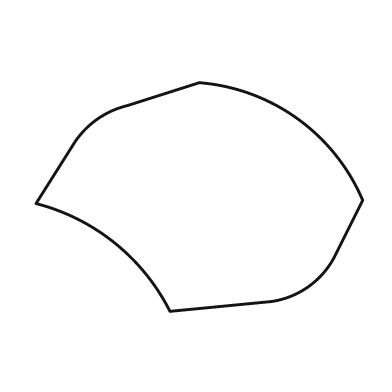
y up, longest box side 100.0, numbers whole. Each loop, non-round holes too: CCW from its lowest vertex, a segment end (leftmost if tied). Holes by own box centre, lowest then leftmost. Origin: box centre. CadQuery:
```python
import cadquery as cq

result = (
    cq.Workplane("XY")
    .moveTo(-9.0, -35.0)
    .lineTo(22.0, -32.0)
    .threePointArc((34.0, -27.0), (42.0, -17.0))
    .lineTo(50.0, -1.0)
    .threePointArc((30.0, 24.0), (0.0, 35.0))
    .lineTo(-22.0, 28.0)
    .threePointArc((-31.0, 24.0), (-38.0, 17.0))
    .lineTo(-50.0, -2.0)
    .threePointArc((-26.0, -14.0), (-9.0, -35.0))
    .close()
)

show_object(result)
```